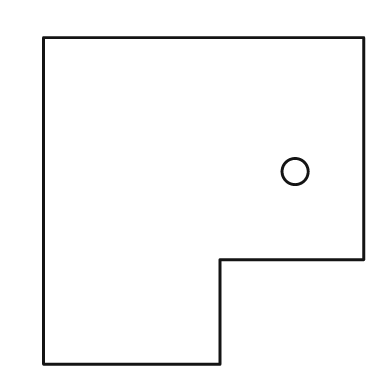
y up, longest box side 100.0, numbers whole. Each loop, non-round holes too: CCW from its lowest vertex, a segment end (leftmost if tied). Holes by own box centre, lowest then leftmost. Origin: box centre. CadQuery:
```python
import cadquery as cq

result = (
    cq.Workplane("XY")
    .moveTo(-49.0, -50.0)
    .lineTo(5.0, -50.0)
    .lineTo(5.0, -18.0)
    .lineTo(49.0, -18.0)
    .lineTo(49.0, 50.0)
    .lineTo(-49.0, 50.0)
    .close()
    .moveTo(28.0, 9.0)
    .circle(4.0)
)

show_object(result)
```